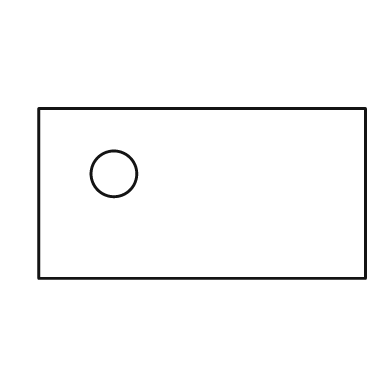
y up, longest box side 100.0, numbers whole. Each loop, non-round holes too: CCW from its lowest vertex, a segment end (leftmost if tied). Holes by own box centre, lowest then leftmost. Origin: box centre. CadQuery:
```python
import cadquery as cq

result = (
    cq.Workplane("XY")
    .moveTo(-50.0, -26.0)
    .lineTo(50.0, -26.0)
    .lineTo(50.0, 26.0)
    .lineTo(-50.0, 26.0)
    .close()
    .moveTo(-27.0, 6.0)
    .circle(7.0)
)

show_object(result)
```